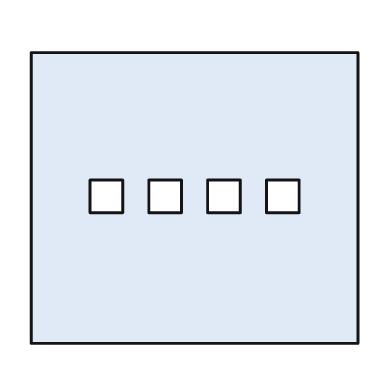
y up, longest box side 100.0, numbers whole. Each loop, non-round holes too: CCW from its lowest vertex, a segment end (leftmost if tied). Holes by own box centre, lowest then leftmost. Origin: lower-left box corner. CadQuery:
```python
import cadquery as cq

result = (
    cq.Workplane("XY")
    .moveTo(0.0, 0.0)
    .lineTo(100.0, 0.0)
    .lineTo(100.0, 89.0)
    .lineTo(0.0, 89.0)
    .close()
    .moveTo(18.0, 40.0)
    .lineTo(28.0, 40.0)
    .lineTo(28.0, 50.0)
    .lineTo(18.0, 50.0)
    .close()
    .moveTo(36.0, 40.0)
    .lineTo(46.0, 40.0)
    .lineTo(46.0, 50.0)
    .lineTo(36.0, 50.0)
    .close()
    .moveTo(54.0, 40.0)
    .lineTo(64.0, 40.0)
    .lineTo(64.0, 50.0)
    .lineTo(54.0, 50.0)
    .close()
    .moveTo(72.0, 40.0)
    .lineTo(82.0, 40.0)
    .lineTo(82.0, 50.0)
    .lineTo(72.0, 50.0)
    .close()
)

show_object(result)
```